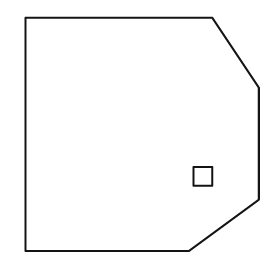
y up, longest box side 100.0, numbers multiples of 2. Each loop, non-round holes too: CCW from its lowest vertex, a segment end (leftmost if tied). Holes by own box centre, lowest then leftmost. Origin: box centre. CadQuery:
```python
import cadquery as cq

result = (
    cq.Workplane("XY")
    .moveTo(-50.0, -50.0)
    .lineTo(20.0, -50.0)
    .lineTo(50.0, -28.0)
    .lineTo(50.0, 20.0)
    .lineTo(30.0, 50.0)
    .lineTo(-50.0, 50.0)
    .close()
    .moveTo(22.0, -22.0)
    .lineTo(30.0, -22.0)
    .lineTo(30.0, -14.0)
    .lineTo(22.0, -14.0)
    .close()
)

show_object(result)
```